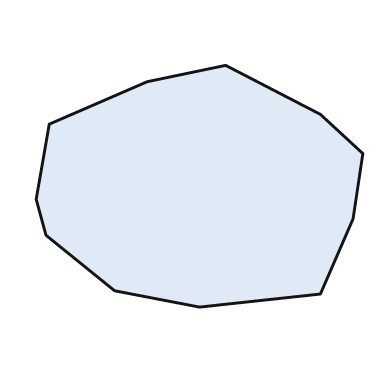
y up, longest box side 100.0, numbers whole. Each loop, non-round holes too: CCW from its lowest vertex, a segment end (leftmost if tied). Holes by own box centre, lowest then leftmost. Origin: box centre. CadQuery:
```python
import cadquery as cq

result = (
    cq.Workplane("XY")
    .moveTo(0.0, -37.0)
    .lineTo(37.0, -33.0)
    .lineTo(47.0, -10.0)
    .lineTo(50.0, 10.0)
    .lineTo(37.0, 22.0)
    .lineTo(8.0, 37.0)
    .lineTo(-16.0, 32.0)
    .lineTo(-46.0, 19.0)
    .lineTo(-50.0, -4.0)
    .lineTo(-47.0, -15.0)
    .lineTo(-26.0, -32.0)
    .close()
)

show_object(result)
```